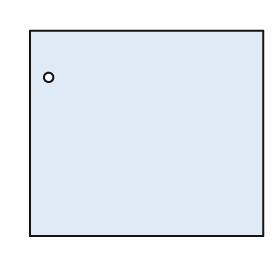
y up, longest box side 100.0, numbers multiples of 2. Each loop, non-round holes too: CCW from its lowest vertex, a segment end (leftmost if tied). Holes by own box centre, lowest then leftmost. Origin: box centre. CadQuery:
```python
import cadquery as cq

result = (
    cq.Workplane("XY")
    .moveTo(-50.0, -44.0)
    .lineTo(50.0, -44.0)
    .lineTo(50.0, 44.0)
    .lineTo(-50.0, 44.0)
    .close()
    .moveTo(-42.0, 24.0)
    .circle(2.0)
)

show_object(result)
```